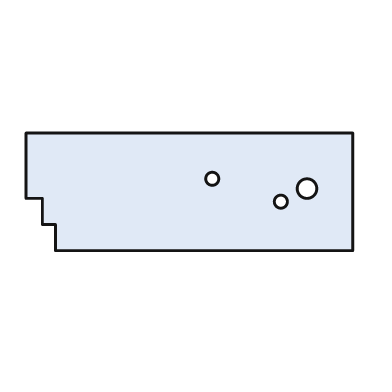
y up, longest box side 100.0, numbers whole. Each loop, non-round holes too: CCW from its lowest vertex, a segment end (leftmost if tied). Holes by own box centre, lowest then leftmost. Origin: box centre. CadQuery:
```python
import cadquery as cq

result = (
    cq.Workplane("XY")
    .moveTo(-41.0, -18.0)
    .lineTo(50.0, -18.0)
    .lineTo(50.0, 18.0)
    .lineTo(-50.0, 18.0)
    .lineTo(-50.0, -2.0)
    .lineTo(-45.0, -2.0)
    .lineTo(-45.0, -10.0)
    .lineTo(-41.0, -10.0)
    .close()
    .moveTo(28.0, -3.0)
    .circle(2.0)
    .moveTo(36.0, 1.0)
    .circle(3.0)
    .moveTo(7.0, 4.0)
    .circle(2.0)
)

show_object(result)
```